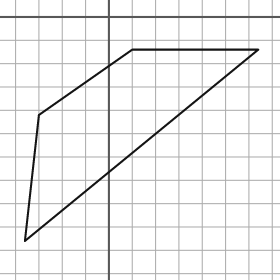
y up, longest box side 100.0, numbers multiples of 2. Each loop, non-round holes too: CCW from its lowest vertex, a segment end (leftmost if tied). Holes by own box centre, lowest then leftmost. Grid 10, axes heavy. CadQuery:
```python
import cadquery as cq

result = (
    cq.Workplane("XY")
    .moveTo(-36.0, -96.0)
    .lineTo(64.0, -14.0)
    .lineTo(10.0, -14.0)
    .lineTo(-30.0, -42.0)
    .close()
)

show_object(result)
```